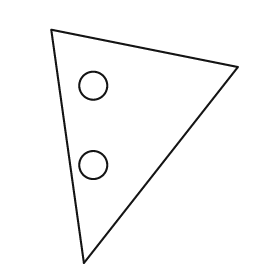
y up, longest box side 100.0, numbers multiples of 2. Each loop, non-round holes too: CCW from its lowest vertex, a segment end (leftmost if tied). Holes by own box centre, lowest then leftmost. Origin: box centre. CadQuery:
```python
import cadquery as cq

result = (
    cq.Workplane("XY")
    .moveTo(-26.0, -50.0)
    .lineTo(40.0, 34.0)
    .lineTo(-40.0, 50.0)
    .close()
    .moveTo(-22.0, -8.0)
    .circle(6.0)
    .moveTo(-22.0, 26.0)
    .circle(6.0)
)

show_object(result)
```